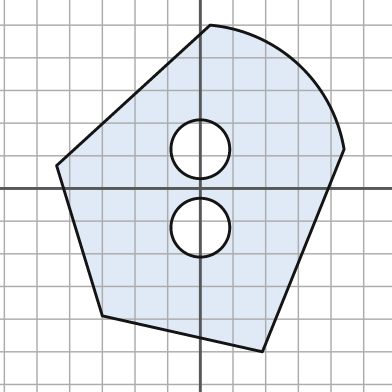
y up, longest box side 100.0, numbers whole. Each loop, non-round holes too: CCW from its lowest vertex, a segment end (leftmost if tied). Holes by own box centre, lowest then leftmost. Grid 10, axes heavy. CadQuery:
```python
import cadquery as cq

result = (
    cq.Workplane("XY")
    .moveTo(19.0, -50.0)
    .lineTo(44.0, 12.0)
    .threePointArc((30.0, 38.0), (3.0, 50.0))
    .lineTo(-44.0, 7.0)
    .lineTo(-30.0, -39.0)
    .close()
    .moveTo(0.0, -12.0)
    .circle(9.0)
    .moveTo(0.0, 12.0)
    .circle(9.0)
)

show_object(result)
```